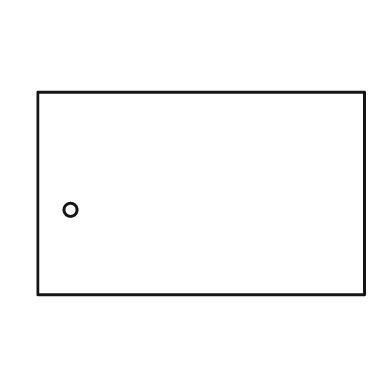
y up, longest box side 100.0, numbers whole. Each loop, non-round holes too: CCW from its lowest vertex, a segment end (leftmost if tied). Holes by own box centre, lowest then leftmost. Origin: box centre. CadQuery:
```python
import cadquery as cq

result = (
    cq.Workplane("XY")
    .moveTo(-50.0, -31.0)
    .lineTo(50.0, -31.0)
    .lineTo(50.0, 31.0)
    .lineTo(-50.0, 31.0)
    .close()
    .moveTo(-40.0, -5.0)
    .circle(2.0)
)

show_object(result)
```